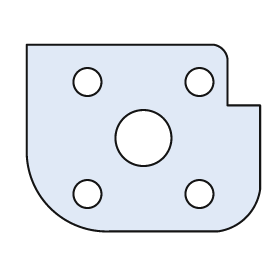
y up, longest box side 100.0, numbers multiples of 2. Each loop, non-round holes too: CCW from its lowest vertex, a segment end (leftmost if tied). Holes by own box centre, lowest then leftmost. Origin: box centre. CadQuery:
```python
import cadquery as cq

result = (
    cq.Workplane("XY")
    .moveTo(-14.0, -40.0)
    .lineTo(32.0, -40.0)
    .threePointArc((44.0, -34.0), (50.0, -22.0))
    .lineTo(50.0, 14.0)
    .lineTo(36.0, 14.0)
    .lineTo(36.0, 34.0)
    .threePointArc((34.0, 38.0), (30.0, 40.0))
    .lineTo(-50.0, 40.0)
    .lineTo(-50.0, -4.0)
    .threePointArc((-40.0, -30.0), (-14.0, -40.0))
    .close()
    .moveTo(-24.0, -24.0)
    .circle(6.0)
    .moveTo(24.0, -24.0)
    .circle(6.0)
    .moveTo(0.0, 0.0)
    .circle(12.0)
    .moveTo(-24.0, 24.0)
    .circle(6.0)
    .moveTo(24.0, 24.0)
    .circle(6.0)
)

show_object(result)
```